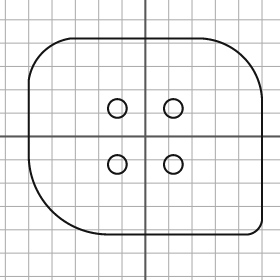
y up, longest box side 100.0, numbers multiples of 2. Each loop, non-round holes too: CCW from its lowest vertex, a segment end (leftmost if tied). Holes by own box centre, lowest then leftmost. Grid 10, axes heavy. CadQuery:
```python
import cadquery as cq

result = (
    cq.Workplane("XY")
    .moveTo(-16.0, -42.0)
    .lineTo(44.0, -42.0)
    .threePointArc((48.0, -40.0), (50.0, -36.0))
    .lineTo(50.0, 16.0)
    .threePointArc((42.0, 34.0), (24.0, 42.0))
    .lineTo(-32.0, 42.0)
    .threePointArc((-44.0, 36.0), (-50.0, 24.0))
    .lineTo(-50.0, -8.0)
    .threePointArc((-40.0, -32.0), (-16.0, -42.0))
    .close()
    .moveTo(-12.0, -12.0)
    .circle(4.0)
    .moveTo(12.0, -12.0)
    .circle(4.0)
    .moveTo(-12.0, 12.0)
    .circle(4.0)
    .moveTo(12.0, 12.0)
    .circle(4.0)
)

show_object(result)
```